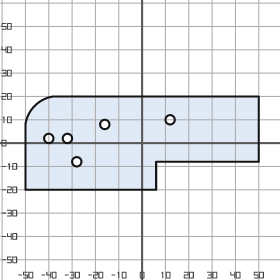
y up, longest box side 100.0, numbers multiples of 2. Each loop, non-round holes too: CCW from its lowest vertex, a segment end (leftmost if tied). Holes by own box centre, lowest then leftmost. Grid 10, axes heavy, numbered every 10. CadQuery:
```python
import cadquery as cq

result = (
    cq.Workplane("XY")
    .moveTo(-50.0, -20.0)
    .lineTo(6.0, -20.0)
    .lineTo(6.0, -8.0)
    .lineTo(50.0, -8.0)
    .lineTo(50.0, 20.0)
    .lineTo(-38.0, 20.0)
    .threePointArc((-46.0, 16.0), (-50.0, 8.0))
    .close()
    .moveTo(-28.0, -8.0)
    .circle(2.0)
    .moveTo(-40.0, 2.0)
    .circle(2.0)
    .moveTo(-32.0, 2.0)
    .circle(2.0)
    .moveTo(-16.0, 8.0)
    .circle(2.0)
    .moveTo(12.0, 10.0)
    .circle(2.0)
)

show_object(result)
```